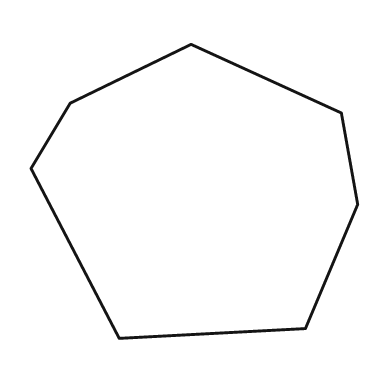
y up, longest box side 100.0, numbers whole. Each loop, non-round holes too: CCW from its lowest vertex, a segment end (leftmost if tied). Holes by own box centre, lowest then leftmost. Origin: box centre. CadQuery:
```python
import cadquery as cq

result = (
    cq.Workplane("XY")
    .moveTo(-23.0, -45.0)
    .lineTo(34.0, -42.0)
    .lineTo(50.0, -4.0)
    .lineTo(45.0, 24.0)
    .lineTo(-1.0, 45.0)
    .lineTo(-38.0, 27.0)
    .lineTo(-50.0, 7.0)
    .close()
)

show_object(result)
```